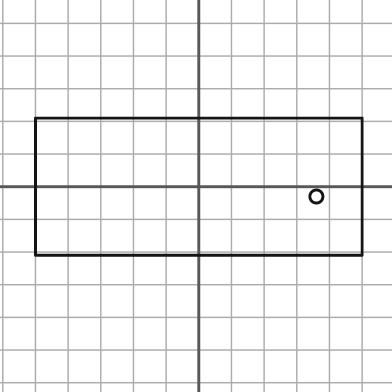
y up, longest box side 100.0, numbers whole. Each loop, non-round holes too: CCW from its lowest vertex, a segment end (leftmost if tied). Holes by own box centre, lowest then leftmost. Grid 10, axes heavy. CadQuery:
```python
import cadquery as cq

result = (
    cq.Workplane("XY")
    .moveTo(-50.0, -21.0)
    .lineTo(50.0, -21.0)
    .lineTo(50.0, 21.0)
    .lineTo(-50.0, 21.0)
    .close()
    .moveTo(36.0, -3.0)
    .circle(2.0)
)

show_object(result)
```